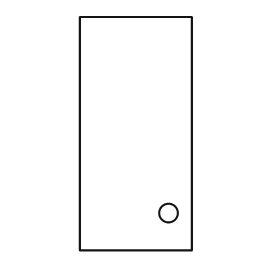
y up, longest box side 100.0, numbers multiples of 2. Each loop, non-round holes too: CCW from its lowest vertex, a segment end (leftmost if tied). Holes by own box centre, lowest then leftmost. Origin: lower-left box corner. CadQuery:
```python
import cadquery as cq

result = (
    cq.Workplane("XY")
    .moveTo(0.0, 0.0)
    .lineTo(48.0, 0.0)
    .lineTo(48.0, 100.0)
    .lineTo(0.0, 100.0)
    .close()
    .moveTo(38.0, 16.0)
    .circle(4.0)
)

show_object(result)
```